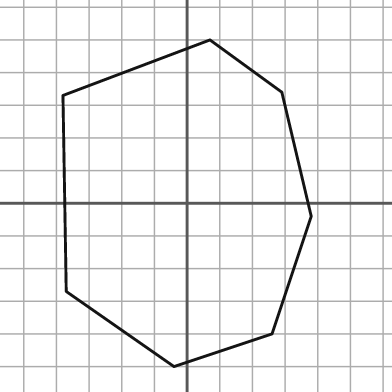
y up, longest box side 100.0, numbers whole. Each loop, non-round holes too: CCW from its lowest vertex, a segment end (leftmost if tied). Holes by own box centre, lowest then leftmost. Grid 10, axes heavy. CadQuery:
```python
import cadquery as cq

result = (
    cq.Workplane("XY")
    .moveTo(-4.0, -50.0)
    .lineTo(26.0, -40.0)
    .lineTo(38.0, -4.0)
    .lineTo(29.0, 34.0)
    .lineTo(7.0, 50.0)
    .lineTo(-38.0, 33.0)
    .lineTo(-37.0, -27.0)
    .close()
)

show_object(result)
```